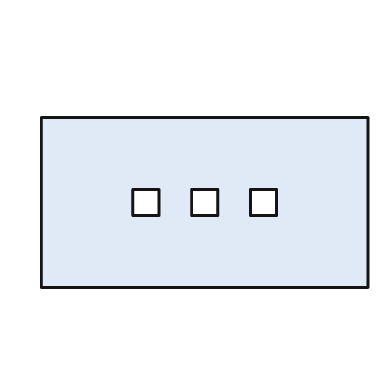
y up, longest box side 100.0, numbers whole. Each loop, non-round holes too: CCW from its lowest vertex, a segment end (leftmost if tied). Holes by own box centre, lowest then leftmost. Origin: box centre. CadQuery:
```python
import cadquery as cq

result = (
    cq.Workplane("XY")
    .moveTo(-50.0, -26.0)
    .lineTo(50.0, -26.0)
    .lineTo(50.0, 26.0)
    .lineTo(-50.0, 26.0)
    .close()
    .moveTo(-22.0, -4.0)
    .lineTo(-14.0, -4.0)
    .lineTo(-14.0, 4.0)
    .lineTo(-22.0, 4.0)
    .close()
    .moveTo(-4.0, -4.0)
    .lineTo(4.0, -4.0)
    .lineTo(4.0, 4.0)
    .lineTo(-4.0, 4.0)
    .close()
    .moveTo(14.0, -4.0)
    .lineTo(22.0, -4.0)
    .lineTo(22.0, 4.0)
    .lineTo(14.0, 4.0)
    .close()
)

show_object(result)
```